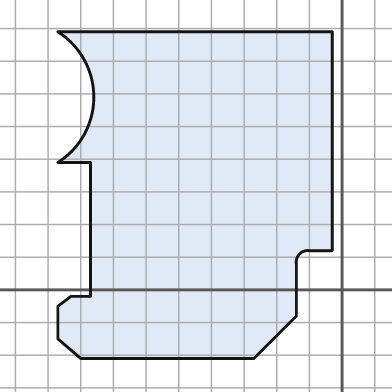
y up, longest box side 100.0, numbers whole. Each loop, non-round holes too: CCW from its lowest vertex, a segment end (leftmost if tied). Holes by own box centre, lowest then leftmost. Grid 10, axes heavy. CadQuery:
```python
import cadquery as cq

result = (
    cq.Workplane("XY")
    .moveTo(-80.0, -21.0)
    .lineTo(-27.0, -21.0)
    .lineTo(-14.0, -8.0)
    .lineTo(-14.0, 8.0)
    .threePointArc((-13.0, 11.0), (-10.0, 12.0))
    .lineTo(-3.0, 12.0)
    .lineTo(-3.0, 79.0)
    .lineTo(-87.0, 79.0)
    .threePointArc((-76.0, 59.0), (-87.0, 39.0))
    .lineTo(-77.0, 39.0)
    .lineTo(-77.0, -2.0)
    .lineTo(-83.0, -2.0)
    .lineTo(-87.0, -5.0)
    .lineTo(-87.0, -15.0)
    .close()
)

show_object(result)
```